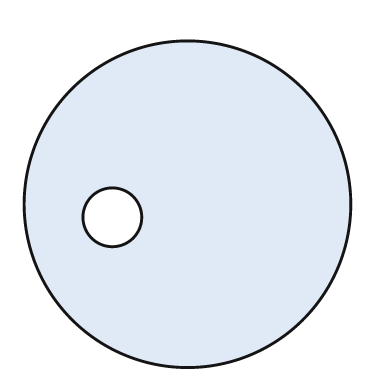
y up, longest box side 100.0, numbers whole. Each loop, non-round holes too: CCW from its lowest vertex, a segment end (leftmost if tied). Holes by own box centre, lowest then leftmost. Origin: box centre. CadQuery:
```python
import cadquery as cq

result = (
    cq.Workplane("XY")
    .moveTo(0.0, 0.0)
    .circle(50.0)
    .moveTo(-23.0, -4.0)
    .circle(9.0)
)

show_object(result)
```